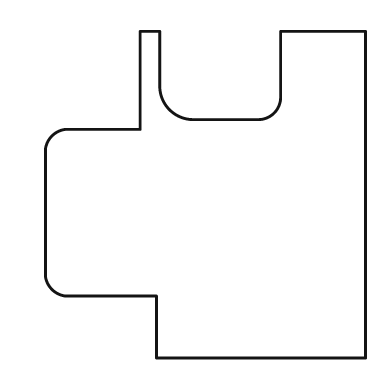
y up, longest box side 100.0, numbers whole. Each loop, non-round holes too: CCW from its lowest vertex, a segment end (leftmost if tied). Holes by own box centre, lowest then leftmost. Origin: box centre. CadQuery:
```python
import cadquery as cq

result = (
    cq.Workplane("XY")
    .moveTo(-15.0, -50.0)
    .lineTo(49.0, -50.0)
    .lineTo(49.0, 50.0)
    .lineTo(23.0, 50.0)
    .lineTo(23.0, 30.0)
    .threePointArc((21.0, 25.0), (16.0, 23.0))
    .lineTo(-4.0, 23.0)
    .threePointArc((-11.0, 26.0), (-14.0, 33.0))
    .lineTo(-14.0, 50.0)
    .lineTo(-20.0, 50.0)
    .lineTo(-20.0, 20.0)
    .lineTo(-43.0, 20.0)
    .threePointArc((-47.0, 18.0), (-49.0, 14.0))
    .lineTo(-49.0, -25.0)
    .threePointArc((-47.0, -29.0), (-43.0, -31.0))
    .lineTo(-15.0, -31.0)
    .close()
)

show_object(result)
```